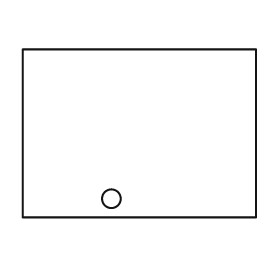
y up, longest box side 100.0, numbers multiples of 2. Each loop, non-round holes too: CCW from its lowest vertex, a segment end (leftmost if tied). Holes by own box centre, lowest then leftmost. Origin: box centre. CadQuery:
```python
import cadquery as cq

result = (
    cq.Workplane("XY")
    .moveTo(-50.0, -36.0)
    .lineTo(50.0, -36.0)
    .lineTo(50.0, 36.0)
    .lineTo(-50.0, 36.0)
    .close()
    .moveTo(-12.0, -28.0)
    .circle(4.0)
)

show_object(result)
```